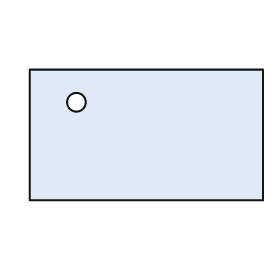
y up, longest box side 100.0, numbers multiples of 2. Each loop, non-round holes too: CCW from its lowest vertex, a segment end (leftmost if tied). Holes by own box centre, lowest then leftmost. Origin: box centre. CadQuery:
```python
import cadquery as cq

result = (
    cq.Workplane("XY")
    .moveTo(-50.0, -28.0)
    .lineTo(50.0, -28.0)
    .lineTo(50.0, 28.0)
    .lineTo(-50.0, 28.0)
    .close()
    .moveTo(-30.0, 14.0)
    .circle(4.0)
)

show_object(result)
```